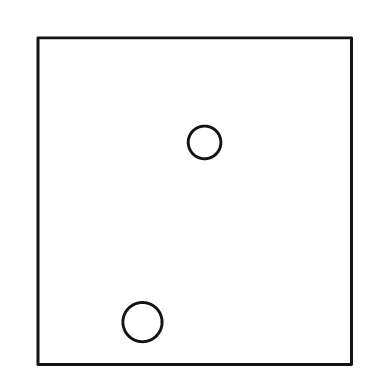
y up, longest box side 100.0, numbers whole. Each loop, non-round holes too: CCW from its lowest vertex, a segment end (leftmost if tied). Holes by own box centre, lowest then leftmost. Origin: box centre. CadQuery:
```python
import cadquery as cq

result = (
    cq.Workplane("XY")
    .moveTo(-48.0, -50.0)
    .lineTo(48.0, -50.0)
    .lineTo(48.0, 50.0)
    .lineTo(-48.0, 50.0)
    .close()
    .moveTo(-16.0, -37.0)
    .circle(6.0)
    .moveTo(3.0, 18.0)
    .circle(5.0)
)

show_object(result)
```